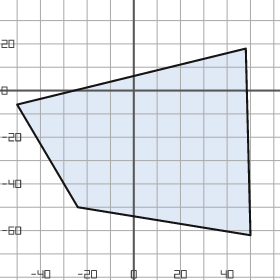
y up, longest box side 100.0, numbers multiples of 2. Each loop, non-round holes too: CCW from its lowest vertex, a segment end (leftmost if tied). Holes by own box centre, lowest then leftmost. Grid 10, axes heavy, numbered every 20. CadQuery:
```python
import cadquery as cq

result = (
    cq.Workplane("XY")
    .moveTo(50.0, -62.0)
    .lineTo(48.0, 18.0)
    .lineTo(-50.0, -6.0)
    .lineTo(-24.0, -50.0)
    .close()
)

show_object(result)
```